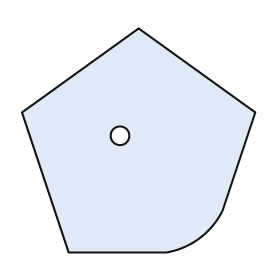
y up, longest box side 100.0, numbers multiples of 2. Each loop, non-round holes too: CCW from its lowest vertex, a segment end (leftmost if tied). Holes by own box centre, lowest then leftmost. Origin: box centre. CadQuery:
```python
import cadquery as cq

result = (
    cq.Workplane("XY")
    .moveTo(-30.0, -48.0)
    .lineTo(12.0, -48.0)
    .threePointArc((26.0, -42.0), (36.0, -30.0))
    .lineTo(50.0, 12.0)
    .lineTo(0.0, 48.0)
    .lineTo(-50.0, 12.0)
    .close()
    .moveTo(-8.0, 2.0)
    .circle(4.0)
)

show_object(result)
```